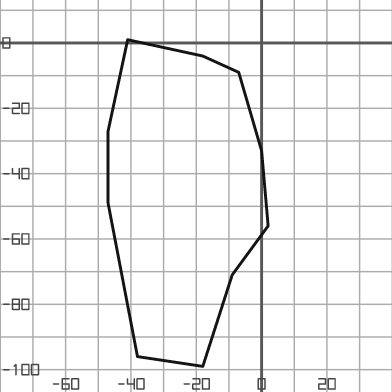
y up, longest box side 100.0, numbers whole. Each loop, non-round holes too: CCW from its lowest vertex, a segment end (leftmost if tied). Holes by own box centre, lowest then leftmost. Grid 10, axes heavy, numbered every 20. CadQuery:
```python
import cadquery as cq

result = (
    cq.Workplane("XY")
    .moveTo(-18.0, -99.0)
    .lineTo(-9.0, -71.0)
    .lineTo(2.0, -56.0)
    .lineTo(0.0, -33.0)
    .lineTo(-7.0, -9.0)
    .lineTo(-18.0, -4.0)
    .lineTo(-41.0, 1.0)
    .lineTo(-47.0, -27.0)
    .lineTo(-47.0, -49.0)
    .lineTo(-38.0, -96.0)
    .close()
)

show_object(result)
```